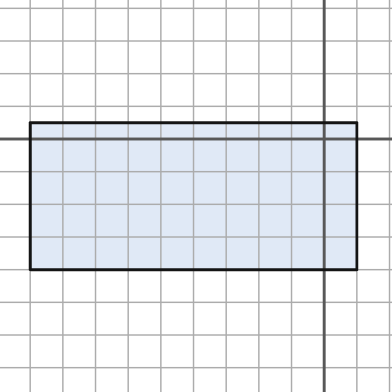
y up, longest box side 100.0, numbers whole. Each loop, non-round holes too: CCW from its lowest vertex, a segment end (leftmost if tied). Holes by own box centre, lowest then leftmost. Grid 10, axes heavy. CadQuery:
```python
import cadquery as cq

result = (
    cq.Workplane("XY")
    .moveTo(-90.0, -40.0)
    .lineTo(10.0, -40.0)
    .lineTo(10.0, 5.0)
    .lineTo(-90.0, 5.0)
    .close()
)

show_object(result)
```